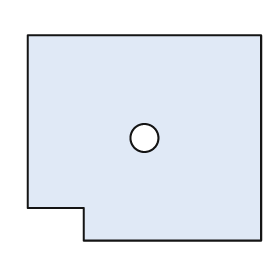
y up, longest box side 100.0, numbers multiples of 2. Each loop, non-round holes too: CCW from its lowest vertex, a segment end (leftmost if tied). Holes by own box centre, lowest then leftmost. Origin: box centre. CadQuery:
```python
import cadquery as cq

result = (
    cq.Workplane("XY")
    .moveTo(-26.0, -44.0)
    .lineTo(50.0, -44.0)
    .lineTo(50.0, 44.0)
    .lineTo(-50.0, 44.0)
    .lineTo(-50.0, -30.0)
    .lineTo(-26.0, -30.0)
    .close()
    .moveTo(0.0, 0.0)
    .circle(6.0)
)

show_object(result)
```